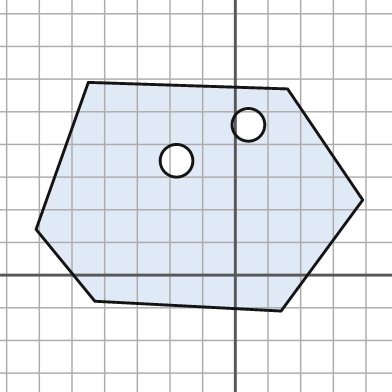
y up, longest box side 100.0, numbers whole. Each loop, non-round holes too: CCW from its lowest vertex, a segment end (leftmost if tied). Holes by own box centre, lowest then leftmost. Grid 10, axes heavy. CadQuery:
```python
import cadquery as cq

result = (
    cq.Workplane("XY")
    .moveTo(14.0, -11.0)
    .lineTo(39.0, 23.0)
    .lineTo(16.0, 57.0)
    .lineTo(-45.0, 59.0)
    .lineTo(-61.0, 14.0)
    .lineTo(-43.0, -8.0)
    .close()
    .moveTo(-18.0, 35.0)
    .circle(5.0)
    .moveTo(4.0, 46.0)
    .circle(5.0)
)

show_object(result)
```